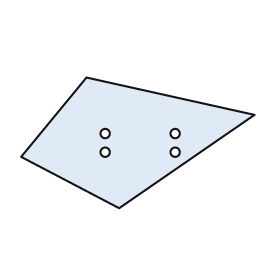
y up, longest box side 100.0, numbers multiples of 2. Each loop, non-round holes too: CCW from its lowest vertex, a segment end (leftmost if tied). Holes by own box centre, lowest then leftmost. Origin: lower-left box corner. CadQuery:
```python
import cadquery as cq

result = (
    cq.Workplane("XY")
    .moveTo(42.0, 0.0)
    .lineTo(100.0, 40.0)
    .lineTo(28.0, 56.0)
    .lineTo(0.0, 22.0)
    .close()
    .moveTo(36.0, 24.0)
    .circle(2.0)
    .moveTo(66.0, 24.0)
    .circle(2.0)
    .moveTo(36.0, 32.0)
    .circle(2.0)
    .moveTo(66.0, 32.0)
    .circle(2.0)
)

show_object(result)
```